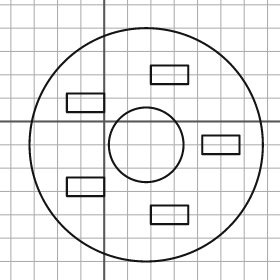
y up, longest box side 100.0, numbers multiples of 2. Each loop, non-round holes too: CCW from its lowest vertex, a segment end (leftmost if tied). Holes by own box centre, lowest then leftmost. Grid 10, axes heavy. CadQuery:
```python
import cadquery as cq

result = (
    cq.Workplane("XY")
    .moveTo(18.0, -10.0)
    .circle(50.0)
    .moveTo(20.0, -44.0)
    .lineTo(36.0, -44.0)
    .lineTo(36.0, -36.0)
    .lineTo(20.0, -36.0)
    .close()
    .moveTo(-16.0, -32.0)
    .lineTo(0.0, -32.0)
    .lineTo(0.0, -24.0)
    .lineTo(-16.0, -24.0)
    .close()
    .moveTo(18.0, -10.0)
    .circle(16.0)
    .moveTo(42.0, -14.0)
    .lineTo(58.0, -14.0)
    .lineTo(58.0, -6.0)
    .lineTo(42.0, -6.0)
    .close()
    .moveTo(-16.0, 4.0)
    .lineTo(0.0, 4.0)
    .lineTo(0.0, 12.0)
    .lineTo(-16.0, 12.0)
    .close()
    .moveTo(20.0, 16.0)
    .lineTo(36.0, 16.0)
    .lineTo(36.0, 24.0)
    .lineTo(20.0, 24.0)
    .close()
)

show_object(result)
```